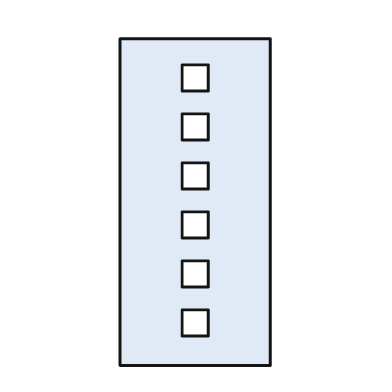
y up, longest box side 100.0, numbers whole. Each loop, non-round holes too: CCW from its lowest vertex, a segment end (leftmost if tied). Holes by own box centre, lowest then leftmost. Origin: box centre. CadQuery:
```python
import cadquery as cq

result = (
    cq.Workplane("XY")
    .moveTo(-23.0, -50.0)
    .lineTo(23.0, -50.0)
    .lineTo(23.0, 50.0)
    .lineTo(-23.0, 50.0)
    .close()
    .moveTo(-4.0, -41.0)
    .lineTo(4.0, -41.0)
    .lineTo(4.0, -33.0)
    .lineTo(-4.0, -33.0)
    .close()
    .moveTo(-4.0, -26.0)
    .lineTo(4.0, -26.0)
    .lineTo(4.0, -18.0)
    .lineTo(-4.0, -18.0)
    .close()
    .moveTo(-4.0, -11.0)
    .lineTo(4.0, -11.0)
    .lineTo(4.0, -3.0)
    .lineTo(-4.0, -3.0)
    .close()
    .moveTo(-4.0, 4.0)
    .lineTo(4.0, 4.0)
    .lineTo(4.0, 12.0)
    .lineTo(-4.0, 12.0)
    .close()
    .moveTo(-4.0, 19.0)
    .lineTo(4.0, 19.0)
    .lineTo(4.0, 27.0)
    .lineTo(-4.0, 27.0)
    .close()
    .moveTo(-4.0, 34.0)
    .lineTo(4.0, 34.0)
    .lineTo(4.0, 42.0)
    .lineTo(-4.0, 42.0)
    .close()
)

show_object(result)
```